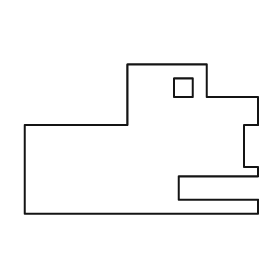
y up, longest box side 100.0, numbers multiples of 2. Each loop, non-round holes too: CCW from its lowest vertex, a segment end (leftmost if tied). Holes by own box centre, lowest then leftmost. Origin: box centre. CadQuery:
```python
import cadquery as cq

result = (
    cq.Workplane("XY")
    .moveTo(-50.0, -32.0)
    .lineTo(50.0, -32.0)
    .lineTo(50.0, -26.0)
    .lineTo(16.0, -26.0)
    .lineTo(16.0, -16.0)
    .lineTo(50.0, -16.0)
    .lineTo(50.0, -12.0)
    .lineTo(44.0, -12.0)
    .lineTo(44.0, 6.0)
    .lineTo(50.0, 6.0)
    .lineTo(50.0, 18.0)
    .lineTo(28.0, 18.0)
    .lineTo(28.0, 32.0)
    .lineTo(-6.0, 32.0)
    .lineTo(-6.0, 6.0)
    .lineTo(-50.0, 6.0)
    .close()
    .moveTo(14.0, 18.0)
    .lineTo(22.0, 18.0)
    .lineTo(22.0, 26.0)
    .lineTo(14.0, 26.0)
    .close()
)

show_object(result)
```